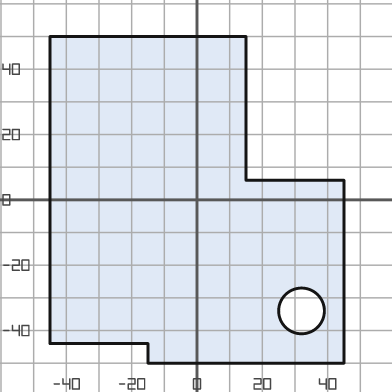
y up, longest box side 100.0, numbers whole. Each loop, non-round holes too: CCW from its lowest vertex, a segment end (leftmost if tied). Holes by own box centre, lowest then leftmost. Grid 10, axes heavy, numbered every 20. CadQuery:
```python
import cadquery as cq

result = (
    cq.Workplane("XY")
    .moveTo(-15.0, -50.0)
    .lineTo(45.0, -50.0)
    .lineTo(45.0, 6.0)
    .lineTo(15.0, 6.0)
    .lineTo(15.0, 50.0)
    .lineTo(-45.0, 50.0)
    .lineTo(-45.0, -44.0)
    .lineTo(-15.0, -44.0)
    .close()
    .moveTo(32.0, -34.0)
    .circle(7.0)
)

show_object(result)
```